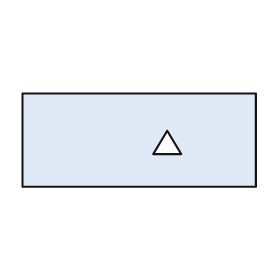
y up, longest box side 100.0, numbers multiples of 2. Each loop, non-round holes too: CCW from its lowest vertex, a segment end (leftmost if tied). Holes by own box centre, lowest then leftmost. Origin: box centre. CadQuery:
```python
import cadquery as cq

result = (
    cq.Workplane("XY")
    .moveTo(-50.0, -20.0)
    .lineTo(50.0, -20.0)
    .lineTo(50.0, 20.0)
    .lineTo(-50.0, 20.0)
    .close()
    .moveTo(6.0, -6.0)
    .lineTo(18.0, -6.0)
    .lineTo(12.0, 4.0)
    .close()
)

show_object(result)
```